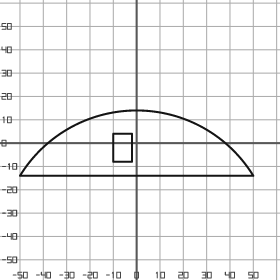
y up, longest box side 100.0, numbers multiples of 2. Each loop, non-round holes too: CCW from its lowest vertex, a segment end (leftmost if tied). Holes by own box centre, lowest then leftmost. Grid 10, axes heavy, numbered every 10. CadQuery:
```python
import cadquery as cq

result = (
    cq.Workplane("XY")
    .moveTo(-50.0, -14.0)
    .lineTo(50.0, -14.0)
    .threePointArc((0.0, 14.0), (-50.0, -14.0))
    .close()
    .moveTo(-10.0, -8.0)
    .lineTo(-2.0, -8.0)
    .lineTo(-2.0, 4.0)
    .lineTo(-10.0, 4.0)
    .close()
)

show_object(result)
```